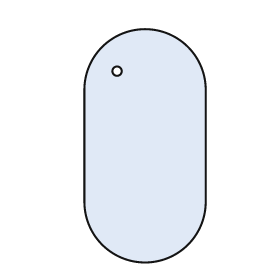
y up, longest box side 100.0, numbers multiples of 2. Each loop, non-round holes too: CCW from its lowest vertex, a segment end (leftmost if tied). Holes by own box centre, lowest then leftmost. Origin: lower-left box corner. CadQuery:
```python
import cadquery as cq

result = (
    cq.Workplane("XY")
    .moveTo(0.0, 26.0)
    .threePointArc((26.0, 0.0), (52.0, 26.0))
    .lineTo(52.0, 74.0)
    .threePointArc((26.0, 100.0), (0.0, 74.0))
    .close()
    .moveTo(14.0, 82.0)
    .circle(2.0)
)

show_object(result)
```